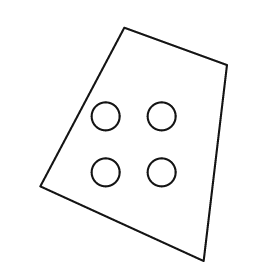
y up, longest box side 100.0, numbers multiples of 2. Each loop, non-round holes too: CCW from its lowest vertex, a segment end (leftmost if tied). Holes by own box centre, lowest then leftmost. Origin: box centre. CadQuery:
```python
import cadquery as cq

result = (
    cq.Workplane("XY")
    .moveTo(30.0, -50.0)
    .lineTo(40.0, 34.0)
    .lineTo(-4.0, 50.0)
    .lineTo(-40.0, -18.0)
    .close()
    .moveTo(-12.0, -12.0)
    .circle(6.0)
    .moveTo(12.0, -12.0)
    .circle(6.0)
    .moveTo(-12.0, 12.0)
    .circle(6.0)
    .moveTo(12.0, 12.0)
    .circle(6.0)
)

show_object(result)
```